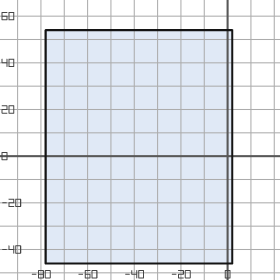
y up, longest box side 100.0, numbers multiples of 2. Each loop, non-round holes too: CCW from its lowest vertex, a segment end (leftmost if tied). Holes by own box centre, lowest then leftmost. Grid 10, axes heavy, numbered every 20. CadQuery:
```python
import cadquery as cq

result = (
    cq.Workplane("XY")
    .moveTo(-78.0, -46.0)
    .lineTo(2.0, -46.0)
    .lineTo(2.0, 54.0)
    .lineTo(-78.0, 54.0)
    .close()
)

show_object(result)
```